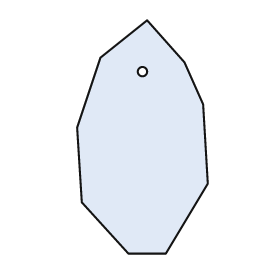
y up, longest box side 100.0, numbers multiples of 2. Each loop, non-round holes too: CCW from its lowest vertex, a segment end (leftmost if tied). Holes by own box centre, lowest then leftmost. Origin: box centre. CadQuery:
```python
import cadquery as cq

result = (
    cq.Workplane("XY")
    .moveTo(-6.0, -50.0)
    .lineTo(10.0, -50.0)
    .lineTo(28.0, -20.0)
    .lineTo(26.0, 14.0)
    .lineTo(18.0, 32.0)
    .lineTo(2.0, 50.0)
    .lineTo(-18.0, 34.0)
    .lineTo(-28.0, 4.0)
    .lineTo(-26.0, -28.0)
    .close()
    .moveTo(0.0, 28.0)
    .circle(2.0)
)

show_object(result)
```